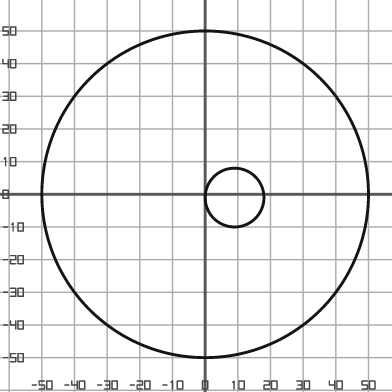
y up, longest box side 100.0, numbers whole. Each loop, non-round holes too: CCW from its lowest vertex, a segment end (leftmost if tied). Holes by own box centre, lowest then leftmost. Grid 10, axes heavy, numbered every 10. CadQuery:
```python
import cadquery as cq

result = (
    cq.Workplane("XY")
    .moveTo(0.0, 0.0)
    .circle(50.0)
    .moveTo(9.0, -1.0)
    .circle(9.0)
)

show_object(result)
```